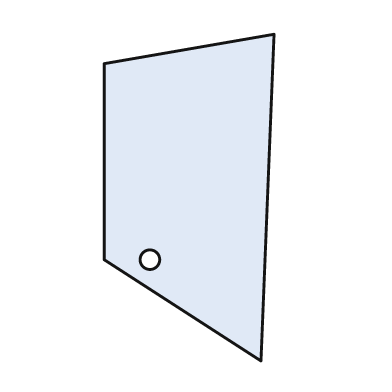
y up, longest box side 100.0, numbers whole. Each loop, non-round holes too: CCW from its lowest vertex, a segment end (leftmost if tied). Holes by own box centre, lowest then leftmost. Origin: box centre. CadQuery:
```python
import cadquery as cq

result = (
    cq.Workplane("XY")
    .moveTo(22.0, -50.0)
    .lineTo(26.0, 50.0)
    .lineTo(-26.0, 41.0)
    .lineTo(-26.0, -19.0)
    .close()
    .moveTo(-12.0, -19.0)
    .circle(3.0)
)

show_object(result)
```